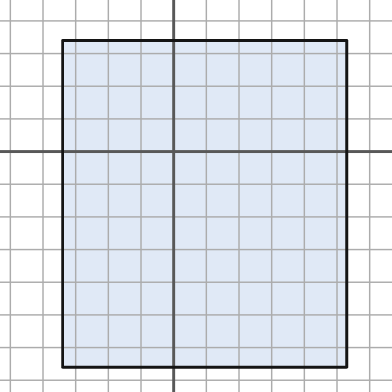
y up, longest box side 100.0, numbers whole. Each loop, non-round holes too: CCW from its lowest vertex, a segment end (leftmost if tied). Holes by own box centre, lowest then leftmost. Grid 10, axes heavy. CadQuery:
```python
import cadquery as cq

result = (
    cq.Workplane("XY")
    .moveTo(-34.0, -66.0)
    .lineTo(53.0, -66.0)
    .lineTo(53.0, 34.0)
    .lineTo(-34.0, 34.0)
    .close()
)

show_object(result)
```